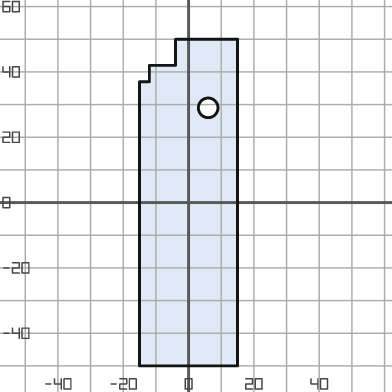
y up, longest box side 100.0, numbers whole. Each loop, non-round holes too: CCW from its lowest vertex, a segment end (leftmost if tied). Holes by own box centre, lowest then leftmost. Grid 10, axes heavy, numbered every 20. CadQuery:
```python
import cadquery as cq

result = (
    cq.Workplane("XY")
    .moveTo(-15.0, -50.0)
    .lineTo(15.0, -50.0)
    .lineTo(15.0, 50.0)
    .lineTo(-4.0, 50.0)
    .lineTo(-4.0, 42.0)
    .lineTo(-12.0, 42.0)
    .lineTo(-12.0, 37.0)
    .lineTo(-15.0, 37.0)
    .close()
    .moveTo(6.0, 29.0)
    .circle(3.0)
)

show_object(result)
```